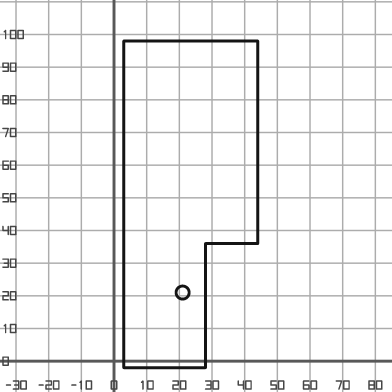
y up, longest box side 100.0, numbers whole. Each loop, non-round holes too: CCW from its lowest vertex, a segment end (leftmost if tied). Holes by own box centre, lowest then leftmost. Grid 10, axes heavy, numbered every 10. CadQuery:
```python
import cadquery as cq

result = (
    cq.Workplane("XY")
    .moveTo(3.0, -2.0)
    .lineTo(28.0, -2.0)
    .lineTo(28.0, 36.0)
    .lineTo(44.0, 36.0)
    .lineTo(44.0, 98.0)
    .lineTo(3.0, 98.0)
    .close()
    .moveTo(21.0, 21.0)
    .circle(2.0)
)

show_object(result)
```